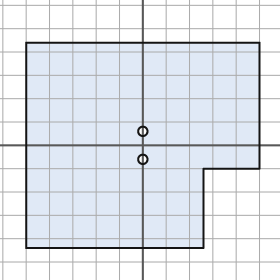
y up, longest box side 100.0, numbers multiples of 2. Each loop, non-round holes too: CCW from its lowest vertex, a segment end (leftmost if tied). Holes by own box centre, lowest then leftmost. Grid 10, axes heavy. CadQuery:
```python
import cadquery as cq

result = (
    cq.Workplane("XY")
    .moveTo(-50.0, -44.0)
    .lineTo(26.0, -44.0)
    .lineTo(26.0, -10.0)
    .lineTo(50.0, -10.0)
    .lineTo(50.0, 44.0)
    .lineTo(-50.0, 44.0)
    .close()
    .moveTo(0.0, -6.0)
    .circle(2.0)
    .moveTo(0.0, 6.0)
    .circle(2.0)
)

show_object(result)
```